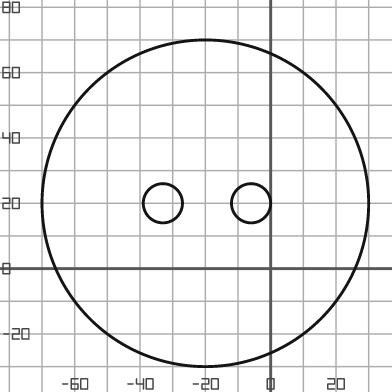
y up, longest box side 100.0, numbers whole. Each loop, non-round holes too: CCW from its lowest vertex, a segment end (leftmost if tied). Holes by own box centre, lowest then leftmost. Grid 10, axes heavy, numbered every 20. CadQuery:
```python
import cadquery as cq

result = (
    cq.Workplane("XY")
    .moveTo(-20.0, 20.0)
    .circle(50.0)
    .moveTo(-33.0, 20.0)
    .circle(6.0)
    .moveTo(-6.0, 20.0)
    .circle(6.0)
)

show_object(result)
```